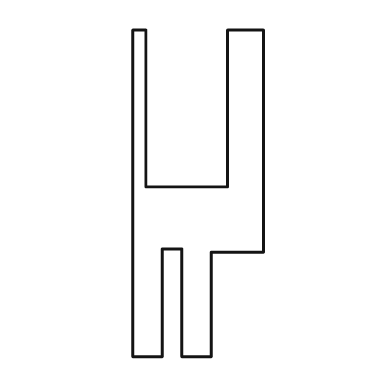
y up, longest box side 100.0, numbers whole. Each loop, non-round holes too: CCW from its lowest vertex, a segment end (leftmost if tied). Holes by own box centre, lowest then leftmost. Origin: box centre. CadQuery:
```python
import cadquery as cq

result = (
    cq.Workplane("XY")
    .moveTo(-20.0, -50.0)
    .lineTo(-11.0, -50.0)
    .lineTo(-11.0, -17.0)
    .lineTo(-5.0, -17.0)
    .lineTo(-5.0, -50.0)
    .lineTo(4.0, -50.0)
    .lineTo(4.0, -18.0)
    .lineTo(20.0, -18.0)
    .lineTo(20.0, 50.0)
    .lineTo(9.0, 50.0)
    .lineTo(9.0, 2.0)
    .lineTo(-16.0, 2.0)
    .lineTo(-16.0, 50.0)
    .lineTo(-20.0, 50.0)
    .close()
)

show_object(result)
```